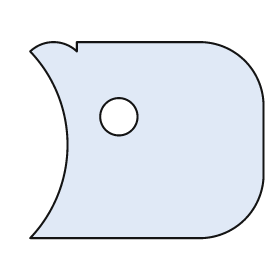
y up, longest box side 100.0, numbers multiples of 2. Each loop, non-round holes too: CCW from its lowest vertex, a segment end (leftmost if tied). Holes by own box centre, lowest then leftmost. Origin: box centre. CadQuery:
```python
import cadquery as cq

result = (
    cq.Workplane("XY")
    .moveTo(-50.0, -42.0)
    .lineTo(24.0, -42.0)
    .threePointArc((42.0, -34.0), (50.0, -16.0))
    .lineTo(50.0, 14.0)
    .threePointArc((42.0, 34.0), (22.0, 42.0))
    .lineTo(-30.0, 42.0)
    .lineTo(-30.0, 38.0)
    .threePointArc((-40.0, 42.0), (-50.0, 38.0))
    .threePointArc((-34.0, -2.0), (-50.0, -42.0))
    .close()
    .moveTo(-12.0, 10.0)
    .circle(8.0)
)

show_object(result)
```